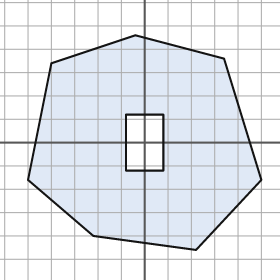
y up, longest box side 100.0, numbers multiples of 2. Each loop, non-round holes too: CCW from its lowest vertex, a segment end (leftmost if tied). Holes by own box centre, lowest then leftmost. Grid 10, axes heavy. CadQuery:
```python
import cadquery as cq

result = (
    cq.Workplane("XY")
    .moveTo(22.0, -46.0)
    .lineTo(50.0, -16.0)
    .lineTo(34.0, 36.0)
    .lineTo(-4.0, 46.0)
    .lineTo(-40.0, 34.0)
    .lineTo(-50.0, -16.0)
    .lineTo(-22.0, -40.0)
    .close()
    .moveTo(-8.0, -12.0)
    .lineTo(8.0, -12.0)
    .lineTo(8.0, 12.0)
    .lineTo(-8.0, 12.0)
    .close()
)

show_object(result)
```